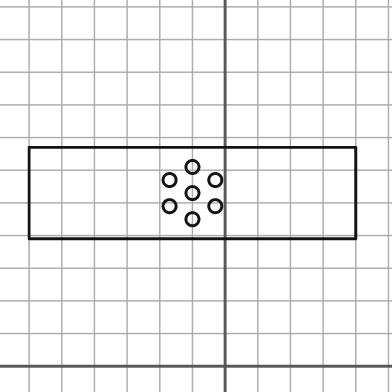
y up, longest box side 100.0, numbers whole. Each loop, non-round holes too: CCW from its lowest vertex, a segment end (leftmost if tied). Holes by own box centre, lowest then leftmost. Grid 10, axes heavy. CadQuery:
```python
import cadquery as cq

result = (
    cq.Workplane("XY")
    .moveTo(-60.0, 39.0)
    .lineTo(40.0, 39.0)
    .lineTo(40.0, 67.0)
    .lineTo(-60.0, 67.0)
    .close()
    .moveTo(-10.0, 45.0)
    .circle(2.0)
    .moveTo(-17.0, 49.0)
    .circle(2.0)
    .moveTo(-3.0, 49.0)
    .circle(2.0)
    .moveTo(-10.0, 53.0)
    .circle(2.0)
    .moveTo(-17.0, 57.0)
    .circle(2.0)
    .moveTo(-3.0, 57.0)
    .circle(2.0)
    .moveTo(-10.0, 61.0)
    .circle(2.0)
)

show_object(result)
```